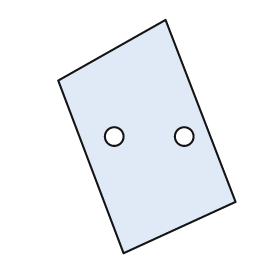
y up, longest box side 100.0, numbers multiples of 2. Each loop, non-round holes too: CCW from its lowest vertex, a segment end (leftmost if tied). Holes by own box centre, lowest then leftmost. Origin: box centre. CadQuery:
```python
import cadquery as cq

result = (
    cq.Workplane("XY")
    .moveTo(-10.0, -50.0)
    .lineTo(38.0, -28.0)
    .lineTo(8.0, 50.0)
    .lineTo(-38.0, 24.0)
    .close()
    .moveTo(-14.0, 0.0)
    .circle(4.0)
    .moveTo(16.0, 0.0)
    .circle(4.0)
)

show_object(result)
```